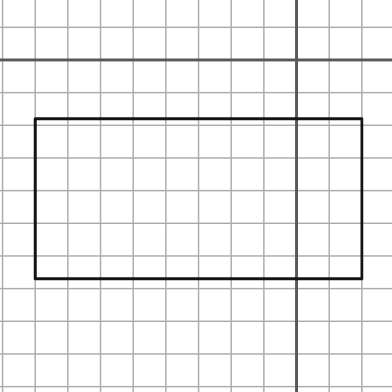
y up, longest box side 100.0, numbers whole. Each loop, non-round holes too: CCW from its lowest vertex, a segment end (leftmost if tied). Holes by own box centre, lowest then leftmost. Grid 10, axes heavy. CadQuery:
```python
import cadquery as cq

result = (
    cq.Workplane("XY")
    .moveTo(-80.0, -67.0)
    .lineTo(20.0, -67.0)
    .lineTo(20.0, -18.0)
    .lineTo(-80.0, -18.0)
    .close()
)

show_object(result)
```